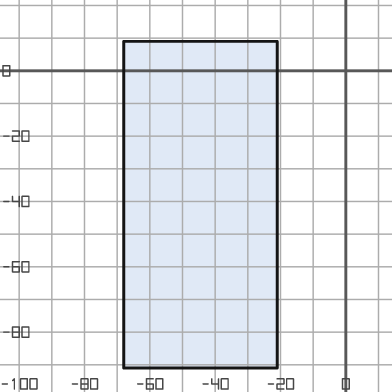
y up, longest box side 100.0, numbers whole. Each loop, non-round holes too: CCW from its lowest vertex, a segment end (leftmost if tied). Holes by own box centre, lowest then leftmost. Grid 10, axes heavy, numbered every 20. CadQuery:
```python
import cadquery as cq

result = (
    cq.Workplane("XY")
    .moveTo(-68.0, -91.0)
    .lineTo(-21.0, -91.0)
    .lineTo(-21.0, 9.0)
    .lineTo(-68.0, 9.0)
    .close()
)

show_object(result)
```